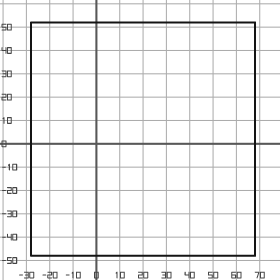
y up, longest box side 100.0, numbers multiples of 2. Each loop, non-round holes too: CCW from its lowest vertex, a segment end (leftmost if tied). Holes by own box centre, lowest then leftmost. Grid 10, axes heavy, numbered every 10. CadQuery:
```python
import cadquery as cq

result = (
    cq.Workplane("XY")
    .moveTo(-28.0, -48.0)
    .lineTo(68.0, -48.0)
    .lineTo(68.0, 52.0)
    .lineTo(-28.0, 52.0)
    .close()
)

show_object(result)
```